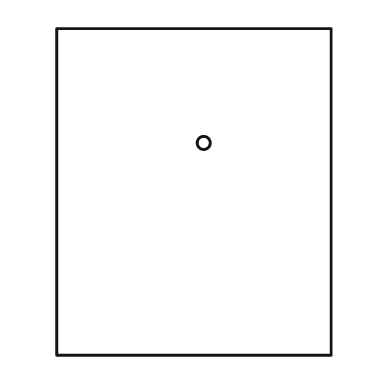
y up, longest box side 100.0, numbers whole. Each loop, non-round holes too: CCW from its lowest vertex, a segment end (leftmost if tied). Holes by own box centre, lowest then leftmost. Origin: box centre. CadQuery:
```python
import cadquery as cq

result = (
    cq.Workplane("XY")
    .moveTo(-42.0, -50.0)
    .lineTo(42.0, -50.0)
    .lineTo(42.0, 50.0)
    .lineTo(-42.0, 50.0)
    .close()
    .moveTo(3.0, 15.0)
    .circle(2.0)
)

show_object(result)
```